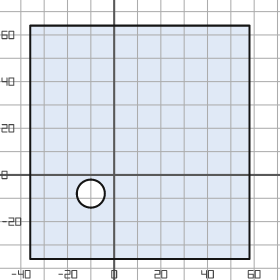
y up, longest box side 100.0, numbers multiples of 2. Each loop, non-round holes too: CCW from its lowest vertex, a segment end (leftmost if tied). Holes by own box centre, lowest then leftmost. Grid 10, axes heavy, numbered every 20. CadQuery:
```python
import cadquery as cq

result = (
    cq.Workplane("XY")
    .moveTo(-36.0, -36.0)
    .lineTo(58.0, -36.0)
    .lineTo(58.0, 64.0)
    .lineTo(-36.0, 64.0)
    .close()
    .moveTo(-10.0, -8.0)
    .circle(6.0)
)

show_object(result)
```